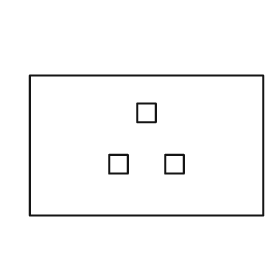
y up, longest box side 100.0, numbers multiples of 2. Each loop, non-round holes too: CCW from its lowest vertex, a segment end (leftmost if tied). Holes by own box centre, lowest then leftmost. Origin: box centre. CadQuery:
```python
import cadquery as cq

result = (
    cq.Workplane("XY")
    .moveTo(-50.0, -30.0)
    .lineTo(50.0, -30.0)
    .lineTo(50.0, 30.0)
    .lineTo(-50.0, 30.0)
    .close()
    .moveTo(-16.0, -12.0)
    .lineTo(-8.0, -12.0)
    .lineTo(-8.0, -4.0)
    .lineTo(-16.0, -4.0)
    .close()
    .moveTo(8.0, -12.0)
    .lineTo(16.0, -12.0)
    .lineTo(16.0, -4.0)
    .lineTo(8.0, -4.0)
    .close()
    .moveTo(-4.0, 10.0)
    .lineTo(4.0, 10.0)
    .lineTo(4.0, 18.0)
    .lineTo(-4.0, 18.0)
    .close()
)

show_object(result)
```